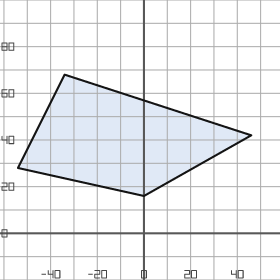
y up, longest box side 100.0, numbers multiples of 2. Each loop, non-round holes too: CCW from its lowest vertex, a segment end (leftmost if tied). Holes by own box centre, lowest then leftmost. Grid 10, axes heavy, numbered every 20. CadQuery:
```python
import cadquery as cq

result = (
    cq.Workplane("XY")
    .moveTo(0.0, 16.0)
    .lineTo(46.0, 42.0)
    .lineTo(-34.0, 68.0)
    .lineTo(-54.0, 28.0)
    .close()
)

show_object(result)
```